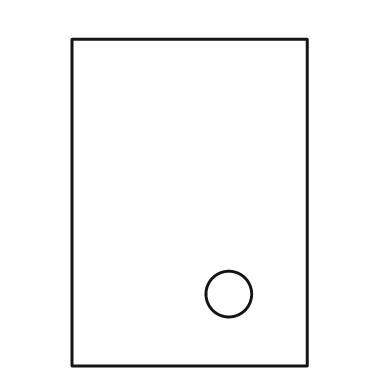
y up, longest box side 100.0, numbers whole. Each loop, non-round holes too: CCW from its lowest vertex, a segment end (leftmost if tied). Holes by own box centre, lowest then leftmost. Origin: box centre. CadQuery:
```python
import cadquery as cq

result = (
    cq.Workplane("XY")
    .moveTo(-36.0, -50.0)
    .lineTo(36.0, -50.0)
    .lineTo(36.0, 50.0)
    .lineTo(-36.0, 50.0)
    .close()
    .moveTo(12.0, -28.0)
    .circle(7.0)
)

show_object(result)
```